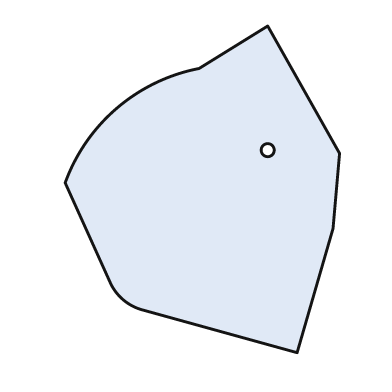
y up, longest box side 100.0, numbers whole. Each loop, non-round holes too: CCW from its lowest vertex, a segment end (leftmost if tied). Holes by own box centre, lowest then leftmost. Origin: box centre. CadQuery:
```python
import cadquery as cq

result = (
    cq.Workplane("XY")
    .moveTo(29.0, -50.0)
    .lineTo(40.0, -12.0)
    .lineTo(42.0, 11.0)
    .lineTo(20.0, 50.0)
    .lineTo(-1.0, 37.0)
    .threePointArc((-26.0, 25.0), (-42.0, 2.0))
    .lineTo(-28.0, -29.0)
    .threePointArc((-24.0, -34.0), (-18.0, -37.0))
    .close()
    .moveTo(20.0, 12.0)
    .circle(2.0)
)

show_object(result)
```